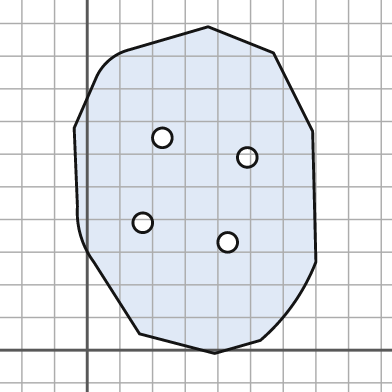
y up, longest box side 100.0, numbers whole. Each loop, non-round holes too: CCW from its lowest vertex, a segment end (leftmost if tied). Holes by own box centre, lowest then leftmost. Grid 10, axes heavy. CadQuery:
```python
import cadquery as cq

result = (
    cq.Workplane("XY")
    .moveTo(39.0, -1.0)
    .lineTo(53.0, 3.0)
    .threePointArc((63.0, 14.0), (70.0, 27.0))
    .lineTo(69.0, 67.0)
    .lineTo(57.0, 91.0)
    .lineTo(37.0, 99.0)
    .lineTo(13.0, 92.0)
    .threePointArc((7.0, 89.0), (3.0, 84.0))
    .lineTo(-4.0, 68.0)
    .lineTo(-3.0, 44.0)
    .threePointArc((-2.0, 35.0), (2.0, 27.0))
    .lineTo(16.0, 5.0)
    .close()
    .moveTo(43.0, 33.0)
    .circle(3.0)
    .moveTo(17.0, 39.0)
    .circle(3.0)
    .moveTo(49.0, 59.0)
    .circle(3.0)
    .moveTo(23.0, 65.0)
    .circle(3.0)
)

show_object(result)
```